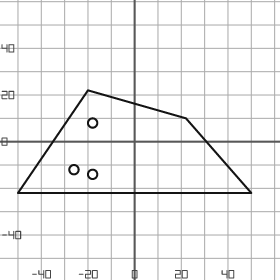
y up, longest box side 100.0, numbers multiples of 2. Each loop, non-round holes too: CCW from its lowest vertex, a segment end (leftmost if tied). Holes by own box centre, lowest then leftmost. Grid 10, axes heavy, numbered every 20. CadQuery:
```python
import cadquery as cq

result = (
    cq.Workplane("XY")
    .moveTo(-50.0, -22.0)
    .lineTo(50.0, -22.0)
    .lineTo(22.0, 10.0)
    .lineTo(-20.0, 22.0)
    .close()
    .moveTo(-18.0, -14.0)
    .circle(2.0)
    .moveTo(-26.0, -12.0)
    .circle(2.0)
    .moveTo(-18.0, 8.0)
    .circle(2.0)
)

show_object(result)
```